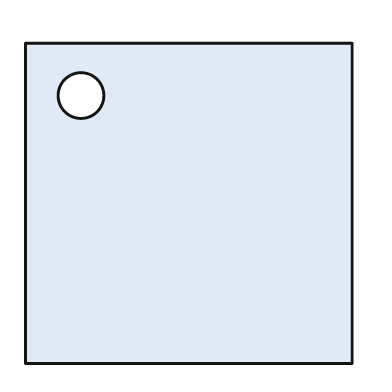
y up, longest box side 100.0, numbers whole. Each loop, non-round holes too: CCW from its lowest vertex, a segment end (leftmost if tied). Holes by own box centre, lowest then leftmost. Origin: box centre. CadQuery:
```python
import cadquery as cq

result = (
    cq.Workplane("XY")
    .moveTo(-50.0, -49.0)
    .lineTo(50.0, -49.0)
    .lineTo(50.0, 49.0)
    .lineTo(-50.0, 49.0)
    .close()
    .moveTo(-33.0, 33.0)
    .circle(7.0)
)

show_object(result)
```